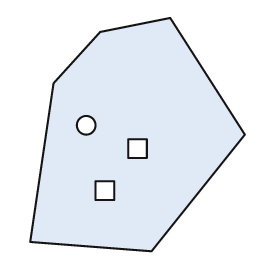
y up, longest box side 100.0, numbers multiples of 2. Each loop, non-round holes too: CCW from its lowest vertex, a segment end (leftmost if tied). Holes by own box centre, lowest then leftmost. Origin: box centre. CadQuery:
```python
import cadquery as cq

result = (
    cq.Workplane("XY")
    .moveTo(6.0, -50.0)
    .lineTo(46.0, 0.0)
    .lineTo(14.0, 50.0)
    .lineTo(-16.0, 44.0)
    .lineTo(-36.0, 22.0)
    .lineTo(-46.0, -46.0)
    .close()
    .moveTo(-18.0, -28.0)
    .lineTo(-10.0, -28.0)
    .lineTo(-10.0, -20.0)
    .lineTo(-18.0, -20.0)
    .close()
    .moveTo(-4.0, -10.0)
    .lineTo(4.0, -10.0)
    .lineTo(4.0, -2.0)
    .lineTo(-4.0, -2.0)
    .close()
    .moveTo(-22.0, 4.0)
    .circle(4.0)
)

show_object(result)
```